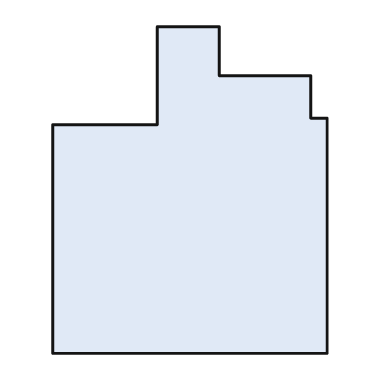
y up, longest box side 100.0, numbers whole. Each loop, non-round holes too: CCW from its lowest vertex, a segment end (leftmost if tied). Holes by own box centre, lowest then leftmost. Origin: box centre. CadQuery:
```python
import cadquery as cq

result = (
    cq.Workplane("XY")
    .moveTo(-42.0, -50.0)
    .lineTo(42.0, -50.0)
    .lineTo(42.0, 22.0)
    .lineTo(37.0, 22.0)
    .lineTo(37.0, 35.0)
    .lineTo(9.0, 35.0)
    .lineTo(9.0, 50.0)
    .lineTo(-10.0, 50.0)
    .lineTo(-10.0, 20.0)
    .lineTo(-42.0, 20.0)
    .close()
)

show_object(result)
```